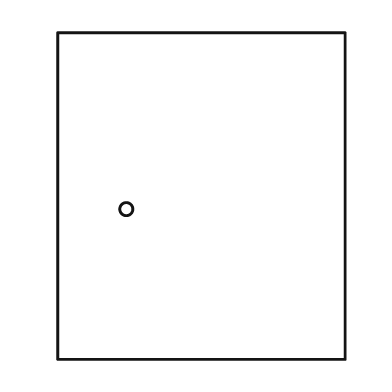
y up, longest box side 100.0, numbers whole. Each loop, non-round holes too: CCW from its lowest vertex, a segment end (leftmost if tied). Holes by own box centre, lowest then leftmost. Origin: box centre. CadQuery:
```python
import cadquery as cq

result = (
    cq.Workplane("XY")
    .moveTo(-44.0, -50.0)
    .lineTo(44.0, -50.0)
    .lineTo(44.0, 50.0)
    .lineTo(-44.0, 50.0)
    .close()
    .moveTo(-23.0, -4.0)
    .circle(2.0)
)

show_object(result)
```